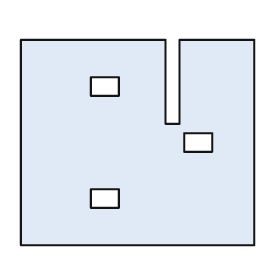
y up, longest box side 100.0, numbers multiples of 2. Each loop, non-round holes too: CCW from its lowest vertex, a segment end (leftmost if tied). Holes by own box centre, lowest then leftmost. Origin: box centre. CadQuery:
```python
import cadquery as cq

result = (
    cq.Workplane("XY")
    .moveTo(-50.0, -44.0)
    .lineTo(50.0, -44.0)
    .lineTo(50.0, 44.0)
    .lineTo(18.0, 44.0)
    .lineTo(18.0, 8.0)
    .lineTo(12.0, 8.0)
    .lineTo(12.0, 44.0)
    .lineTo(-50.0, 44.0)
    .close()
    .moveTo(-20.0, -28.0)
    .lineTo(-8.0, -28.0)
    .lineTo(-8.0, -20.0)
    .lineTo(-20.0, -20.0)
    .close()
    .moveTo(20.0, -4.0)
    .lineTo(32.0, -4.0)
    .lineTo(32.0, 4.0)
    .lineTo(20.0, 4.0)
    .close()
    .moveTo(-20.0, 20.0)
    .lineTo(-8.0, 20.0)
    .lineTo(-8.0, 28.0)
    .lineTo(-20.0, 28.0)
    .close()
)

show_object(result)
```